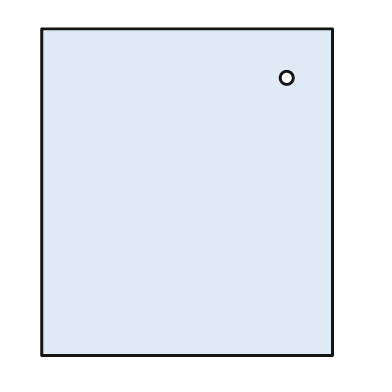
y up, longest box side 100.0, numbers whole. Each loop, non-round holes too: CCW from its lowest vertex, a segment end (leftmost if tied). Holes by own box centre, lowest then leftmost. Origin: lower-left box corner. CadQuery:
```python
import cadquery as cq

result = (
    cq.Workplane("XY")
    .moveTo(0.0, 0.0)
    .lineTo(89.0, 0.0)
    .lineTo(89.0, 100.0)
    .lineTo(0.0, 100.0)
    .close()
    .moveTo(75.0, 85.0)
    .circle(2.0)
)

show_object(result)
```